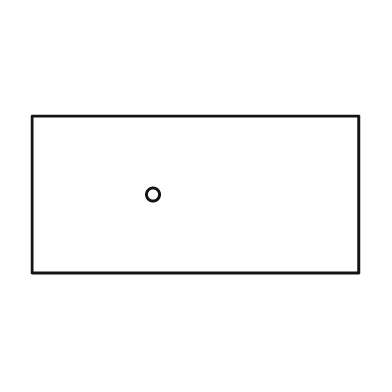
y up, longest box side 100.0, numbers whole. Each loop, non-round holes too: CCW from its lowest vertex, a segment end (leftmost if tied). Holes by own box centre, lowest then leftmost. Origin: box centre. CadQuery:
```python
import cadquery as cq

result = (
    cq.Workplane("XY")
    .moveTo(-50.0, -24.0)
    .lineTo(50.0, -24.0)
    .lineTo(50.0, 24.0)
    .lineTo(-50.0, 24.0)
    .close()
    .moveTo(-13.0, 0.0)
    .circle(2.0)
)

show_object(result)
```